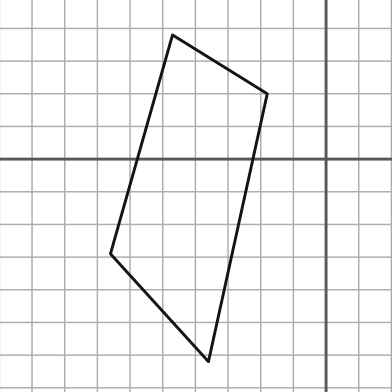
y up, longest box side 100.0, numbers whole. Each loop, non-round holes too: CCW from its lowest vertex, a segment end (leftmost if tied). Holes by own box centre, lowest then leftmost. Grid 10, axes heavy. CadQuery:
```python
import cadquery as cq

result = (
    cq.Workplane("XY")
    .moveTo(-36.0, -62.0)
    .lineTo(-18.0, 20.0)
    .lineTo(-47.0, 38.0)
    .lineTo(-66.0, -29.0)
    .close()
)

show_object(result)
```